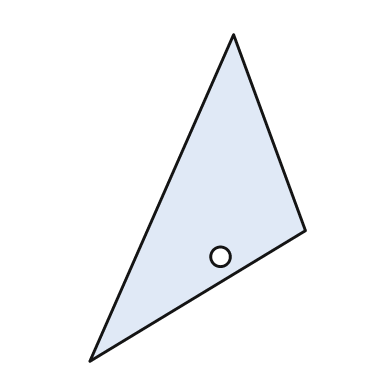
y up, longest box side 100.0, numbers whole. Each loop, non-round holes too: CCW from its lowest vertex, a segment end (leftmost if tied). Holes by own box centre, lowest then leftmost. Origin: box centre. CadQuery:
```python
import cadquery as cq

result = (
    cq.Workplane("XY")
    .moveTo(-33.0, -50.0)
    .lineTo(33.0, -10.0)
    .lineTo(11.0, 50.0)
    .close()
    .moveTo(7.0, -18.0)
    .circle(3.0)
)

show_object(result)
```